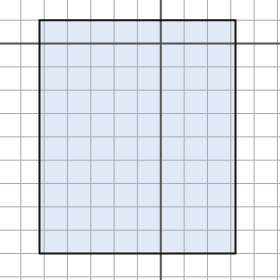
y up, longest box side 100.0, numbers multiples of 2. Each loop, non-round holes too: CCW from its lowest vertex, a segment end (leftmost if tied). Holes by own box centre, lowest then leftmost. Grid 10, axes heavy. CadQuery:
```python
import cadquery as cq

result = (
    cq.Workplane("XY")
    .moveTo(-52.0, -90.0)
    .lineTo(32.0, -90.0)
    .lineTo(32.0, 10.0)
    .lineTo(-52.0, 10.0)
    .close()
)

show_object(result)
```